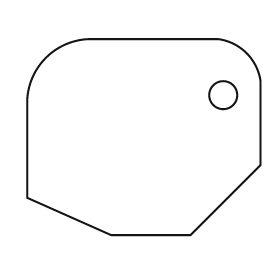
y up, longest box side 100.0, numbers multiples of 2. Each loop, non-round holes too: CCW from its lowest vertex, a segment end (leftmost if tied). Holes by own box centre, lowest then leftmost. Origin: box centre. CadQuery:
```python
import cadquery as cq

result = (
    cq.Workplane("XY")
    .moveTo(-14.0, -42.0)
    .lineTo(20.0, -42.0)
    .lineTo(50.0, -12.0)
    .lineTo(50.0, 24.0)
    .threePointArc((44.0, 36.0), (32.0, 42.0))
    .lineTo(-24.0, 42.0)
    .threePointArc((-42.0, 34.0), (-50.0, 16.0))
    .lineTo(-50.0, -26.0)
    .close()
    .moveTo(34.0, 18.0)
    .circle(6.0)
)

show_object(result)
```